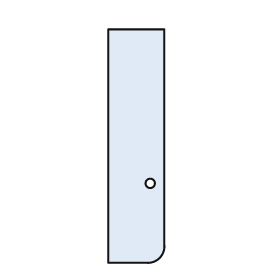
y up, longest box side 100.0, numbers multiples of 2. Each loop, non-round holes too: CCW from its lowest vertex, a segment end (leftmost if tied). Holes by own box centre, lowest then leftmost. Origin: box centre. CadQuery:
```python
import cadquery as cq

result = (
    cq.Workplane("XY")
    .moveTo(-12.0, -50.0)
    .lineTo(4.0, -50.0)
    .threePointArc((10.0, -48.0), (12.0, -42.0))
    .lineTo(12.0, 50.0)
    .lineTo(-12.0, 50.0)
    .close()
    .moveTo(6.0, -16.0)
    .circle(2.0)
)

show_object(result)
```